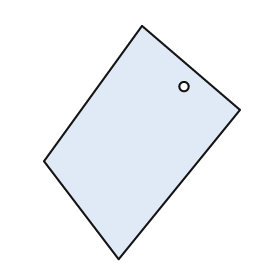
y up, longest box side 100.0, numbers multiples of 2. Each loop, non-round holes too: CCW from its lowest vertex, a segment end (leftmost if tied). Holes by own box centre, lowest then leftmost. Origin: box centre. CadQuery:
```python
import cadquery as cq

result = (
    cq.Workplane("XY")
    .moveTo(-10.0, -50.0)
    .lineTo(42.0, 14.0)
    .lineTo(0.0, 50.0)
    .lineTo(-42.0, -8.0)
    .close()
    .moveTo(18.0, 24.0)
    .circle(2.0)
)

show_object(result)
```